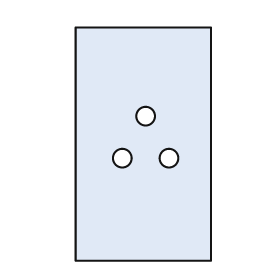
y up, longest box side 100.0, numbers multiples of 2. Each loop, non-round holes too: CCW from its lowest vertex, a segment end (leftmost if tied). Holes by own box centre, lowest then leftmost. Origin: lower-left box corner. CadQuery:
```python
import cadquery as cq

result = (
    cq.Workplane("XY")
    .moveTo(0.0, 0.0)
    .lineTo(58.0, 0.0)
    .lineTo(58.0, 100.0)
    .lineTo(0.0, 100.0)
    .close()
    .moveTo(20.0, 44.0)
    .circle(4.0)
    .moveTo(40.0, 44.0)
    .circle(4.0)
    .moveTo(30.0, 62.0)
    .circle(4.0)
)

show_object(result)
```